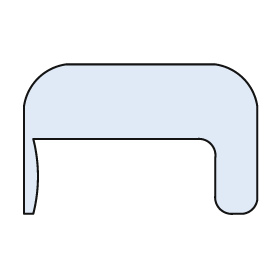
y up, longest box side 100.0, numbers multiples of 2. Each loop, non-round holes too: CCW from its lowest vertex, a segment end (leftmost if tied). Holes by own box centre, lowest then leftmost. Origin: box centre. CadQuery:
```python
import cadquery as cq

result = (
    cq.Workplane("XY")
    .moveTo(-50.0, -32.0)
    .lineTo(-46.0, -32.0)
    .threePointArc((-44.0, -16.0), (-46.0, 0.0))
    .lineTo(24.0, 0.0)
    .threePointArc((30.0, -2.0), (32.0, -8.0))
    .lineTo(32.0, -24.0)
    .threePointArc((34.0, -30.0), (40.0, -32.0))
    .lineTo(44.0, -32.0)
    .threePointArc((48.0, -30.0), (50.0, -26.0))
    .lineTo(50.0, 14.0)
    .threePointArc((44.0, 26.0), (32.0, 32.0))
    .lineTo(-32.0, 32.0)
    .threePointArc((-44.0, 26.0), (-50.0, 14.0))
    .close()
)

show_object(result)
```